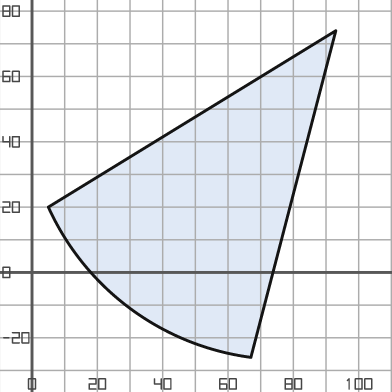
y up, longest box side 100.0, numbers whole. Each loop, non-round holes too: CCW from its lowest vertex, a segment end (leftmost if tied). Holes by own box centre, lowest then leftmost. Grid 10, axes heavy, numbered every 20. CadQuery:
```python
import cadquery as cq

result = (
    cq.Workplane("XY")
    .moveTo(67.0, -26.0)
    .lineTo(93.0, 74.0)
    .lineTo(5.0, 20.0)
    .threePointArc((30.0, -11.0), (67.0, -26.0))
    .close()
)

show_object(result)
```